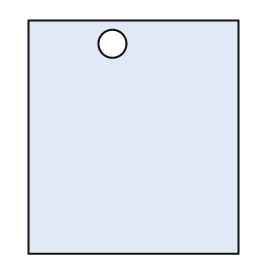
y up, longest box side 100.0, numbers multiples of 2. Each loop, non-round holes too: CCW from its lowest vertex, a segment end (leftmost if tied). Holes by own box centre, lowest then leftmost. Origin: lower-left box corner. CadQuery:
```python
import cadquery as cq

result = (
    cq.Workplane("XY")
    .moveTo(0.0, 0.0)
    .lineTo(90.0, 0.0)
    .lineTo(90.0, 100.0)
    .lineTo(0.0, 100.0)
    .close()
    .moveTo(36.0, 90.0)
    .circle(6.0)
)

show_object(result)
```